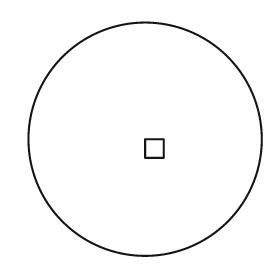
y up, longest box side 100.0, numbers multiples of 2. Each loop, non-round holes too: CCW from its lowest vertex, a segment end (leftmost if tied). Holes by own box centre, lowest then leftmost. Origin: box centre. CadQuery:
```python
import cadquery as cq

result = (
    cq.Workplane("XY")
    .moveTo(0.0, 0.0)
    .circle(50.0)
    .moveTo(0.0, -8.0)
    .lineTo(8.0, -8.0)
    .lineTo(8.0, 0.0)
    .lineTo(0.0, 0.0)
    .close()
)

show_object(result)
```